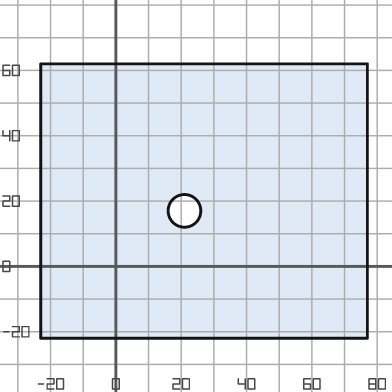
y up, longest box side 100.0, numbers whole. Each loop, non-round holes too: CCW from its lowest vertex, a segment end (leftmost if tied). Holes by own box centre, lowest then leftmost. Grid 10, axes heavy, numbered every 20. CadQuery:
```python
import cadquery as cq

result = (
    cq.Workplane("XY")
    .moveTo(-23.0, -22.0)
    .lineTo(77.0, -22.0)
    .lineTo(77.0, 62.0)
    .lineTo(-23.0, 62.0)
    .close()
    .moveTo(21.0, 17.0)
    .circle(5.0)
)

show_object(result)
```